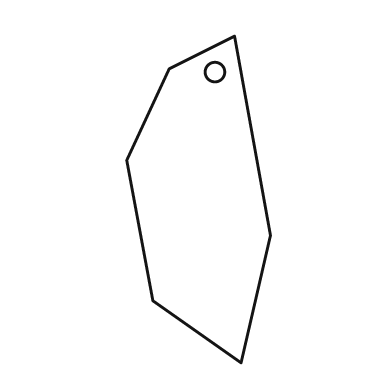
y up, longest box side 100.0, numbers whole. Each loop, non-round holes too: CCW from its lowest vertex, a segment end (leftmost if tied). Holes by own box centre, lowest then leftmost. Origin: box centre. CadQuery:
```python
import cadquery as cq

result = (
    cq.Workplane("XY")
    .moveTo(13.0, -50.0)
    .lineTo(22.0, -11.0)
    .lineTo(11.0, 50.0)
    .lineTo(-9.0, 40.0)
    .lineTo(-22.0, 12.0)
    .lineTo(-14.0, -31.0)
    .close()
    .moveTo(5.0, 39.0)
    .circle(3.0)
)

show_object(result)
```